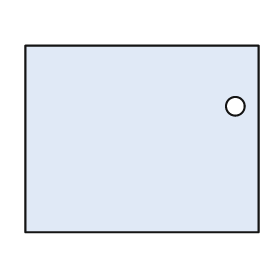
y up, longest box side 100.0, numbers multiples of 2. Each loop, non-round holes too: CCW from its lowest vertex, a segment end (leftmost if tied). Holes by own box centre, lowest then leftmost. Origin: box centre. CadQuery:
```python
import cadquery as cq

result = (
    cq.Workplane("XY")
    .moveTo(-50.0, -40.0)
    .lineTo(50.0, -40.0)
    .lineTo(50.0, 40.0)
    .lineTo(-50.0, 40.0)
    .close()
    .moveTo(40.0, 14.0)
    .circle(4.0)
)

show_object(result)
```